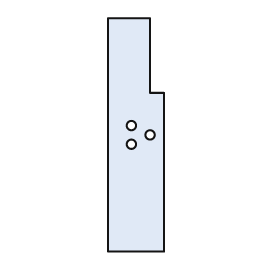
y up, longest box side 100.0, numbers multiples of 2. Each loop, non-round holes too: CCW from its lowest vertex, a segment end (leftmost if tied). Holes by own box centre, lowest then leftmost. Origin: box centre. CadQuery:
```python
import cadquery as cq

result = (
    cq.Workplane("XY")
    .moveTo(-12.0, -50.0)
    .lineTo(12.0, -50.0)
    .lineTo(12.0, 18.0)
    .lineTo(6.0, 18.0)
    .lineTo(6.0, 50.0)
    .lineTo(-12.0, 50.0)
    .close()
    .moveTo(-2.0, -4.0)
    .circle(2.0)
    .moveTo(6.0, 0.0)
    .circle(2.0)
    .moveTo(-2.0, 4.0)
    .circle(2.0)
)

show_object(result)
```